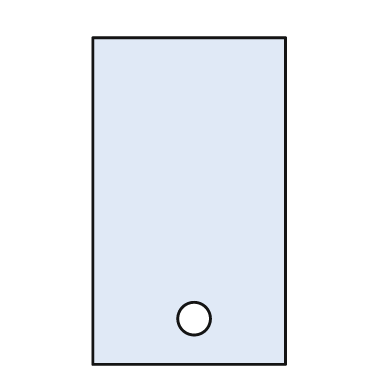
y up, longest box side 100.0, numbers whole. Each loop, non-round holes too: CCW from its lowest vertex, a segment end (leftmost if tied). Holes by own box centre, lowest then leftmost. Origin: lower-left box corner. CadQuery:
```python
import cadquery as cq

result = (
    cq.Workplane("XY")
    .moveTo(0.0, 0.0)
    .lineTo(59.0, 0.0)
    .lineTo(59.0, 100.0)
    .lineTo(0.0, 100.0)
    .close()
    .moveTo(31.0, 14.0)
    .circle(5.0)
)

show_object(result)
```